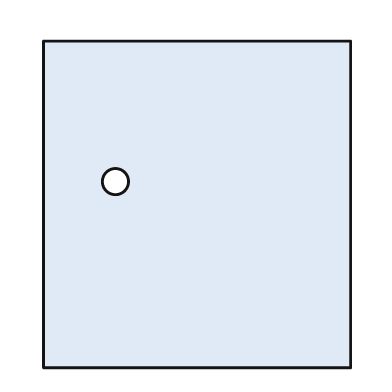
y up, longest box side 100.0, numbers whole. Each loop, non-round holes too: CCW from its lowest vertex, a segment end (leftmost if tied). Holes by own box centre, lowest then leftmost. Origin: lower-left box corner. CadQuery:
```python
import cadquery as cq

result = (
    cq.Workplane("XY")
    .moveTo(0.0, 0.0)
    .lineTo(94.0, 0.0)
    .lineTo(94.0, 100.0)
    .lineTo(0.0, 100.0)
    .close()
    .moveTo(22.0, 57.0)
    .circle(4.0)
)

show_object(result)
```